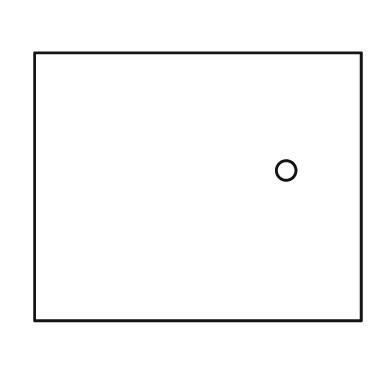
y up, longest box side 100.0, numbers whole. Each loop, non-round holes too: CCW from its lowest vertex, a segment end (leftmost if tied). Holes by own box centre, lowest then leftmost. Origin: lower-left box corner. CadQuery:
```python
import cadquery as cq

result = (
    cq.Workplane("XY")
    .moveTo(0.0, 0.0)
    .lineTo(100.0, 0.0)
    .lineTo(100.0, 82.0)
    .lineTo(0.0, 82.0)
    .close()
    .moveTo(77.0, 46.0)
    .circle(3.0)
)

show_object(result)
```